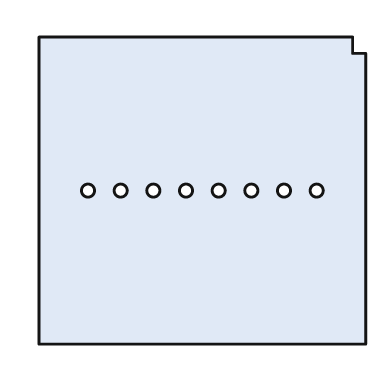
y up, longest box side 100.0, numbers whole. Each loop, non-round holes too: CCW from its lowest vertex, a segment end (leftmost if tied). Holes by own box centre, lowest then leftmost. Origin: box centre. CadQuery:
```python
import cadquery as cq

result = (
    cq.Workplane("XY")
    .moveTo(-50.0, -47.0)
    .lineTo(50.0, -47.0)
    .lineTo(50.0, 42.0)
    .lineTo(46.0, 42.0)
    .lineTo(46.0, 47.0)
    .lineTo(-50.0, 47.0)
    .close()
    .moveTo(-35.0, 0.0)
    .circle(2.0)
    .moveTo(-25.0, 0.0)
    .circle(2.0)
    .moveTo(-15.0, 0.0)
    .circle(2.0)
    .moveTo(-5.0, 0.0)
    .circle(2.0)
    .moveTo(5.0, 0.0)
    .circle(2.0)
    .moveTo(15.0, 0.0)
    .circle(2.0)
    .moveTo(25.0, 0.0)
    .circle(2.0)
    .moveTo(35.0, 0.0)
    .circle(2.0)
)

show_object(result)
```